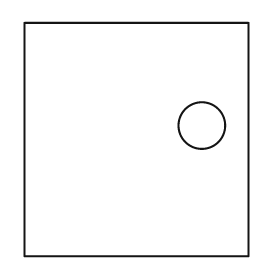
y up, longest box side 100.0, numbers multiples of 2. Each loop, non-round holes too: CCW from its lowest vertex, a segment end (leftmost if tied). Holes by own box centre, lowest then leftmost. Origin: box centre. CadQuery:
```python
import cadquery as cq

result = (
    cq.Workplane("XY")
    .moveTo(-48.0, -50.0)
    .lineTo(48.0, -50.0)
    .lineTo(48.0, 50.0)
    .lineTo(-48.0, 50.0)
    .close()
    .moveTo(28.0, 6.0)
    .circle(10.0)
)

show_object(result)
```